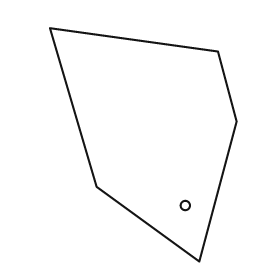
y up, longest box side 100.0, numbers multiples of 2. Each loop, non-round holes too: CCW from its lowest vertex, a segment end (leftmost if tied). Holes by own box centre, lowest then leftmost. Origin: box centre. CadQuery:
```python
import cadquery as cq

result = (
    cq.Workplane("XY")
    .moveTo(24.0, -50.0)
    .lineTo(40.0, 10.0)
    .lineTo(32.0, 40.0)
    .lineTo(-40.0, 50.0)
    .lineTo(-20.0, -18.0)
    .close()
    .moveTo(18.0, -26.0)
    .circle(2.0)
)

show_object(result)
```